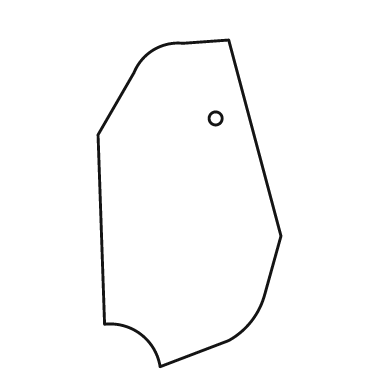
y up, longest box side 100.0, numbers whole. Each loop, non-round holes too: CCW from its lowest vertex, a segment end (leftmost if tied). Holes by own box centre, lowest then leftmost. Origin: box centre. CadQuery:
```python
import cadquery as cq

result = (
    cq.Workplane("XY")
    .moveTo(-9.0, -50.0)
    .lineTo(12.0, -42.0)
    .threePointArc((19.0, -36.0), (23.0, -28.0))
    .lineTo(28.0, -10.0)
    .lineTo(12.0, 50.0)
    .lineTo(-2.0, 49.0)
    .threePointArc((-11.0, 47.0), (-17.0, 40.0))
    .lineTo(-28.0, 21.0)
    .lineTo(-26.0, -37.0)
    .threePointArc((-15.0, -40.0), (-9.0, -50.0))
    .close()
    .moveTo(8.0, 26.0)
    .circle(2.0)
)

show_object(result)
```